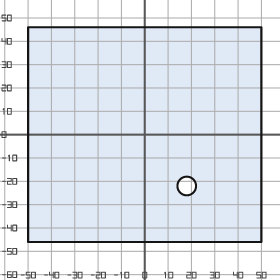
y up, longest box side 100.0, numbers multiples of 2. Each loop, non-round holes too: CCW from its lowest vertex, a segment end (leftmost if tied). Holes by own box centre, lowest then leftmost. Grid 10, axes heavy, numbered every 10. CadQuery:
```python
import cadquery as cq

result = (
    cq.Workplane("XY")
    .moveTo(-50.0, -46.0)
    .lineTo(50.0, -46.0)
    .lineTo(50.0, 46.0)
    .lineTo(-50.0, 46.0)
    .close()
    .moveTo(18.0, -22.0)
    .circle(4.0)
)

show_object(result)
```